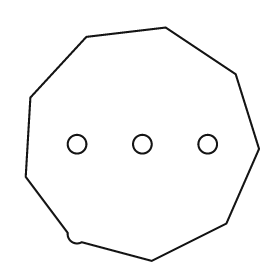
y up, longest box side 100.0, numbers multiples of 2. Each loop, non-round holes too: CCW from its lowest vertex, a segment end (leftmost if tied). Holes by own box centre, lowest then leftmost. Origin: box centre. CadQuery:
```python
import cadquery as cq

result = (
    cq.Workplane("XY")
    .moveTo(4.0, -50.0)
    .lineTo(36.0, -34.0)
    .lineTo(50.0, -2.0)
    .lineTo(40.0, 30.0)
    .lineTo(10.0, 50.0)
    .lineTo(-24.0, 46.0)
    .lineTo(-48.0, 20.0)
    .lineTo(-50.0, -14.0)
    .lineTo(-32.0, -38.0)
    .threePointArc((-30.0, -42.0), (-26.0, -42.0))
    .close()
    .moveTo(-28.0, 0.0)
    .circle(4.0)
    .moveTo(0.0, 0.0)
    .circle(4.0)
    .moveTo(28.0, 0.0)
    .circle(4.0)
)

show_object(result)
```